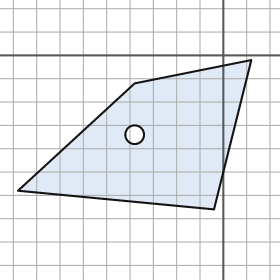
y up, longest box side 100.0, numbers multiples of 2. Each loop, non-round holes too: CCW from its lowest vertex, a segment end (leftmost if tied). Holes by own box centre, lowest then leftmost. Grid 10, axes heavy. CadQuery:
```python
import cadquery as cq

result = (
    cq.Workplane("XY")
    .moveTo(-4.0, -66.0)
    .lineTo(12.0, -2.0)
    .lineTo(-38.0, -12.0)
    .lineTo(-88.0, -58.0)
    .close()
    .moveTo(-38.0, -34.0)
    .circle(4.0)
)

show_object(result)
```